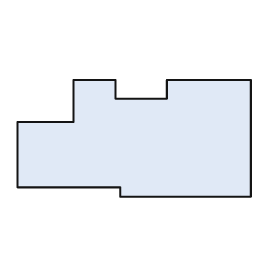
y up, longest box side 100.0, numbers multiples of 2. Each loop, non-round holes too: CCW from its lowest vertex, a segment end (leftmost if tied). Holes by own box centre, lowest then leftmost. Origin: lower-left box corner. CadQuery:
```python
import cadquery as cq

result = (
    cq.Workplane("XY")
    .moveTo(44.0, 0.0)
    .lineTo(100.0, 0.0)
    .lineTo(100.0, 50.0)
    .lineTo(64.0, 50.0)
    .lineTo(64.0, 42.0)
    .lineTo(42.0, 42.0)
    .lineTo(42.0, 50.0)
    .lineTo(24.0, 50.0)
    .lineTo(24.0, 32.0)
    .lineTo(0.0, 32.0)
    .lineTo(0.0, 4.0)
    .lineTo(44.0, 4.0)
    .close()
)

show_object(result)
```